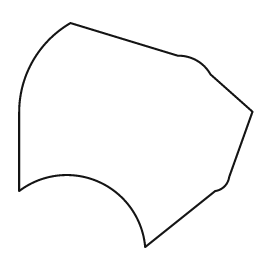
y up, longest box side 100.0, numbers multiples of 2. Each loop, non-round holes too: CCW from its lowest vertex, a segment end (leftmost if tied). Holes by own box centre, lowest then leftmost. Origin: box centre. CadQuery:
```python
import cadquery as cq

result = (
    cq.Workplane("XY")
    .moveTo(4.0, -48.0)
    .lineTo(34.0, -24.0)
    .threePointArc((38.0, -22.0), (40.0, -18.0))
    .lineTo(50.0, 10.0)
    .lineTo(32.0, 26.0)
    .threePointArc((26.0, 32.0), (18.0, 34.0))
    .lineTo(-28.0, 48.0)
    .threePointArc((-44.0, 32.0), (-50.0, 10.0))
    .lineTo(-50.0, -24.0)
    .threePointArc((-16.0, -20.0), (4.0, -48.0))
    .close()
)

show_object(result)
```